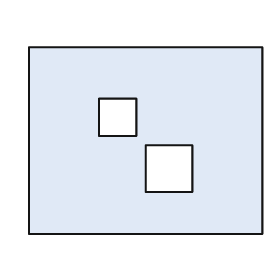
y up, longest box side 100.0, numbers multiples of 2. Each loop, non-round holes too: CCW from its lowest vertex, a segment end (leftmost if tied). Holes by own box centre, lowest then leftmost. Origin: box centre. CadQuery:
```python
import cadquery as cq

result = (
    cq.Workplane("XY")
    .moveTo(-50.0, -40.0)
    .lineTo(50.0, -40.0)
    .lineTo(50.0, 40.0)
    .lineTo(-50.0, 40.0)
    .close()
    .moveTo(0.0, -22.0)
    .lineTo(20.0, -22.0)
    .lineTo(20.0, -2.0)
    .lineTo(0.0, -2.0)
    .close()
    .moveTo(-20.0, 2.0)
    .lineTo(-4.0, 2.0)
    .lineTo(-4.0, 18.0)
    .lineTo(-20.0, 18.0)
    .close()
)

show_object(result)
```